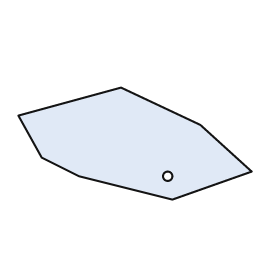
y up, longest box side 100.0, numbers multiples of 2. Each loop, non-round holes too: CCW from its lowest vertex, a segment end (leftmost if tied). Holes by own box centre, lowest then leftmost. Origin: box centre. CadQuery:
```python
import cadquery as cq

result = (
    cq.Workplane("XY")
    .moveTo(16.0, -24.0)
    .lineTo(50.0, -12.0)
    .lineTo(28.0, 8.0)
    .lineTo(-6.0, 24.0)
    .lineTo(-50.0, 12.0)
    .lineTo(-40.0, -6.0)
    .lineTo(-24.0, -14.0)
    .close()
    .moveTo(14.0, -14.0)
    .circle(2.0)
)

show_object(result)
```